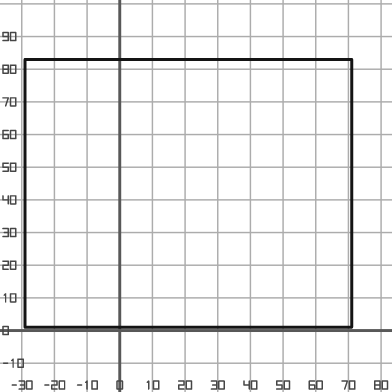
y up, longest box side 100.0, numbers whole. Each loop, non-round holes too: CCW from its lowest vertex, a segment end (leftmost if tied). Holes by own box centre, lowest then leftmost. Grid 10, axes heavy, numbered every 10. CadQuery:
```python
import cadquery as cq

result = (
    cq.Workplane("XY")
    .moveTo(-29.0, 1.0)
    .lineTo(71.0, 1.0)
    .lineTo(71.0, 83.0)
    .lineTo(-29.0, 83.0)
    .close()
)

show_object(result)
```